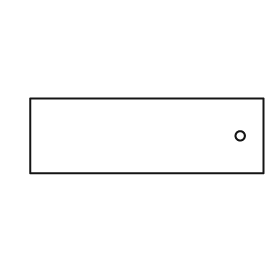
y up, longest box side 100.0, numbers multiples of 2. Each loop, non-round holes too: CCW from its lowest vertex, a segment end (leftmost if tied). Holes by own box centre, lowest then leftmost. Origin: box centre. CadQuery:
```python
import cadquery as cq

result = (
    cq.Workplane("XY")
    .moveTo(-50.0, -16.0)
    .lineTo(50.0, -16.0)
    .lineTo(50.0, 16.0)
    .lineTo(-50.0, 16.0)
    .close()
    .moveTo(40.0, 0.0)
    .circle(2.0)
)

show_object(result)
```